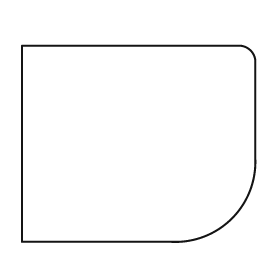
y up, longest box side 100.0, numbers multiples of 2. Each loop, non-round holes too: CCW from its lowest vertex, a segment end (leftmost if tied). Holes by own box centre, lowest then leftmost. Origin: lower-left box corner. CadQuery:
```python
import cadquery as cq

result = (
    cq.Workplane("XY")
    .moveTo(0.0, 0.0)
    .lineTo(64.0, 0.0)
    .threePointArc((90.0, 10.0), (100.0, 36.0))
    .lineTo(100.0, 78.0)
    .threePointArc((98.0, 82.0), (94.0, 84.0))
    .lineTo(0.0, 84.0)
    .close()
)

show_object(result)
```